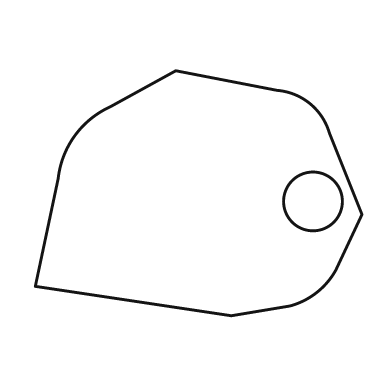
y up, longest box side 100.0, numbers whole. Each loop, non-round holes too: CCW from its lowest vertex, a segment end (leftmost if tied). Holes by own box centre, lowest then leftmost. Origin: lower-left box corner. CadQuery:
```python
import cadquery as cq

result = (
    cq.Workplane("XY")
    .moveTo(60.0, 0.0)
    .lineTo(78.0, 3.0)
    .threePointArc((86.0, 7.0), (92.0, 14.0))
    .lineTo(100.0, 31.0)
    .lineTo(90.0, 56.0)
    .threePointArc((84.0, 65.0), (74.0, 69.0))
    .lineTo(43.0, 75.0)
    .lineTo(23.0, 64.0)
    .threePointArc((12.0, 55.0), (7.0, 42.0))
    .lineTo(0.0, 9.0)
    .close()
    .moveTo(85.0, 35.0)
    .circle(9.0)
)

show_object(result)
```